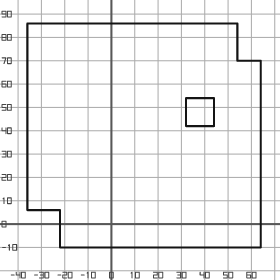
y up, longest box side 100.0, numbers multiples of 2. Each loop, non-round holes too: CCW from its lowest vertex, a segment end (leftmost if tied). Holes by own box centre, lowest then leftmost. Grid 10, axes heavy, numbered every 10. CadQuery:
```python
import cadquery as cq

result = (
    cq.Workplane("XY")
    .moveTo(-22.0, -10.0)
    .lineTo(64.0, -10.0)
    .lineTo(64.0, 70.0)
    .lineTo(54.0, 70.0)
    .lineTo(54.0, 86.0)
    .lineTo(-36.0, 86.0)
    .lineTo(-36.0, 6.0)
    .lineTo(-22.0, 6.0)
    .close()
    .moveTo(32.0, 42.0)
    .lineTo(44.0, 42.0)
    .lineTo(44.0, 54.0)
    .lineTo(32.0, 54.0)
    .close()
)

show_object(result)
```